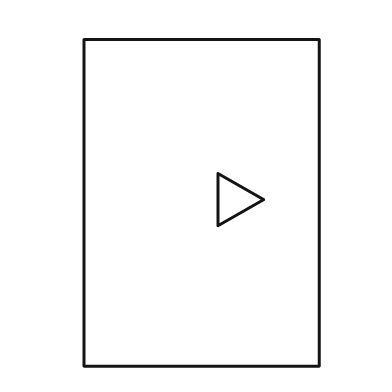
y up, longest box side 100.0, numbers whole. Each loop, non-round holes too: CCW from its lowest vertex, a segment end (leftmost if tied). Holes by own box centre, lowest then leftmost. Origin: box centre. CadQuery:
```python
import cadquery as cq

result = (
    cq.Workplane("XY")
    .moveTo(-36.0, -50.0)
    .lineTo(36.0, -50.0)
    .lineTo(36.0, 50.0)
    .lineTo(-36.0, 50.0)
    .close()
    .moveTo(5.0, -7.0)
    .lineTo(19.0, 1.0)
    .lineTo(5.0, 9.0)
    .close()
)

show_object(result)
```